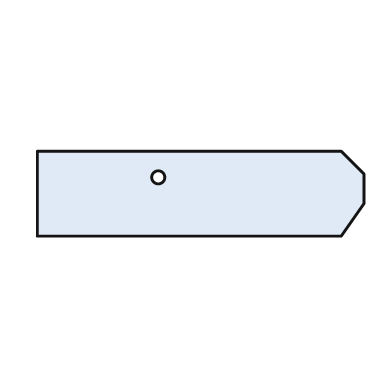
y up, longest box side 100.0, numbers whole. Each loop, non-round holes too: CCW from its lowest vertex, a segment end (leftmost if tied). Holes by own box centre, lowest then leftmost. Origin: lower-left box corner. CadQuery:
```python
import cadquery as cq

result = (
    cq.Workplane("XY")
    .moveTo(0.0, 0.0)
    .lineTo(93.0, 0.0)
    .lineTo(100.0, 10.0)
    .lineTo(100.0, 19.0)
    .lineTo(93.0, 26.0)
    .lineTo(0.0, 26.0)
    .close()
    .moveTo(37.0, 18.0)
    .circle(2.0)
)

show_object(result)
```